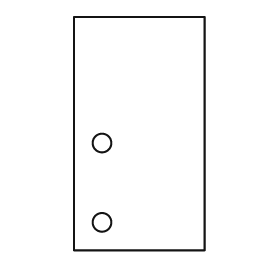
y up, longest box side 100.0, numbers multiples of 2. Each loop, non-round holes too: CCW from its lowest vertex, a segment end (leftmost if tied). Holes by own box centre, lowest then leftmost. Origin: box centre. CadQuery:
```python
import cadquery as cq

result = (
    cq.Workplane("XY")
    .moveTo(-28.0, -50.0)
    .lineTo(28.0, -50.0)
    .lineTo(28.0, 50.0)
    .lineTo(-28.0, 50.0)
    .close()
    .moveTo(-16.0, -38.0)
    .circle(4.0)
    .moveTo(-16.0, -4.0)
    .circle(4.0)
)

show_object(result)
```